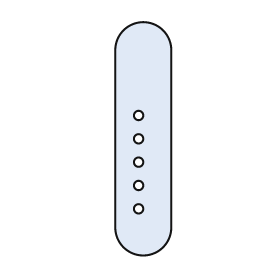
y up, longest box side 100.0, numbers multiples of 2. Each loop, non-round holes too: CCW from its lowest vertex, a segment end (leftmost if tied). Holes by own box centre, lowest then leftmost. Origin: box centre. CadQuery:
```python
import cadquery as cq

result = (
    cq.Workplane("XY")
    .moveTo(-12.0, -38.0)
    .threePointArc((0.0, -50.0), (12.0, -38.0))
    .lineTo(12.0, 38.0)
    .threePointArc((0.0, 50.0), (-12.0, 38.0))
    .close()
    .moveTo(-2.0, -30.0)
    .circle(2.0)
    .moveTo(-2.0, -20.0)
    .circle(2.0)
    .moveTo(-2.0, -10.0)
    .circle(2.0)
    .moveTo(-2.0, 0.0)
    .circle(2.0)
    .moveTo(-2.0, 10.0)
    .circle(2.0)
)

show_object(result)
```